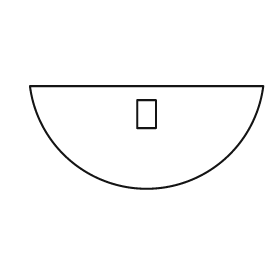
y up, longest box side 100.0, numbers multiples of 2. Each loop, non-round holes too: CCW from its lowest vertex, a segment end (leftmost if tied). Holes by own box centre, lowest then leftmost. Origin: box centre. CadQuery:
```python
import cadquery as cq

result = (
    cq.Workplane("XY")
    .moveTo(-50.0, 22.0)
    .threePointArc((0.0, -22.0), (50.0, 22.0))
    .close()
    .moveTo(-4.0, 4.0)
    .lineTo(4.0, 4.0)
    .lineTo(4.0, 16.0)
    .lineTo(-4.0, 16.0)
    .close()
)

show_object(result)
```